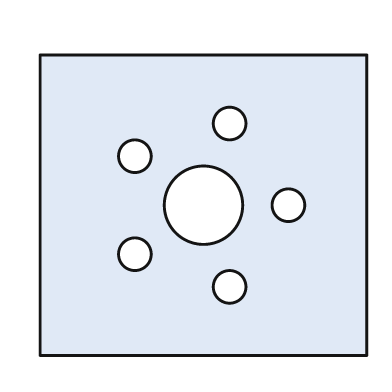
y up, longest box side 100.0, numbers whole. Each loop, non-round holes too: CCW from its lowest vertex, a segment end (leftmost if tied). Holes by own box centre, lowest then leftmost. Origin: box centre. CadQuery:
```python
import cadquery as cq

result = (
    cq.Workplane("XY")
    .moveTo(-50.0, -46.0)
    .lineTo(50.0, -46.0)
    .lineTo(50.0, 46.0)
    .lineTo(-50.0, 46.0)
    .close()
    .moveTo(8.0, -25.0)
    .circle(5.0)
    .moveTo(-21.0, -15.0)
    .circle(5.0)
    .moveTo(0.0, 0.0)
    .circle(12.0)
    .moveTo(26.0, 0.0)
    .circle(5.0)
    .moveTo(-21.0, 15.0)
    .circle(5.0)
    .moveTo(8.0, 25.0)
    .circle(5.0)
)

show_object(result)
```